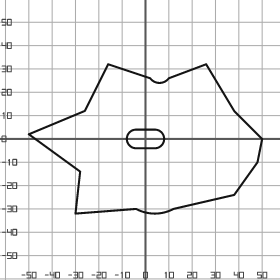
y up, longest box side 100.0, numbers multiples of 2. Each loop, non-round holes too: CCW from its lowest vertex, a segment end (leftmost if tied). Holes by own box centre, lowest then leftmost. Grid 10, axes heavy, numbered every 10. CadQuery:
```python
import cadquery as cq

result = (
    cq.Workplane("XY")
    .moveTo(-30.0, -32.0)
    .lineTo(-4.0, -30.0)
    .threePointArc((4.0, -32.0), (12.0, -30.0))
    .lineTo(38.0, -24.0)
    .lineTo(48.0, -10.0)
    .lineTo(50.0, 0.0)
    .lineTo(38.0, 12.0)
    .lineTo(26.0, 32.0)
    .lineTo(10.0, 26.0)
    .threePointArc((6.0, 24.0), (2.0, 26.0))
    .lineTo(-16.0, 32.0)
    .lineTo(-26.0, 12.0)
    .lineTo(-50.0, 2.0)
    .lineTo(-28.0, -14.0)
    .close()
    .moveTo(-4.0, -4.0)
    .lineTo(4.0, -4.0)
    .threePointArc((8.0, 0.0), (4.0, 4.0))
    .lineTo(-4.0, 4.0)
    .threePointArc((-8.0, 0.0), (-4.0, -4.0))
    .close()
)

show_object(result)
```